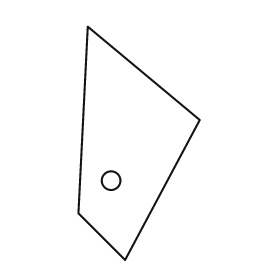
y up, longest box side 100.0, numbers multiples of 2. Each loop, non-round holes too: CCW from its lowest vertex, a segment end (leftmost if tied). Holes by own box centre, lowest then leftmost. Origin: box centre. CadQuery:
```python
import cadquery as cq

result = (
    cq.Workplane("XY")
    .moveTo(-6.0, -50.0)
    .lineTo(26.0, 10.0)
    .lineTo(-22.0, 50.0)
    .lineTo(-26.0, -30.0)
    .close()
    .moveTo(-12.0, -16.0)
    .circle(4.0)
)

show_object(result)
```